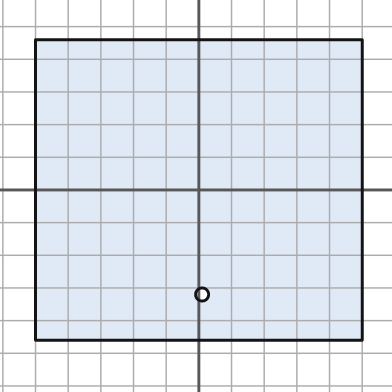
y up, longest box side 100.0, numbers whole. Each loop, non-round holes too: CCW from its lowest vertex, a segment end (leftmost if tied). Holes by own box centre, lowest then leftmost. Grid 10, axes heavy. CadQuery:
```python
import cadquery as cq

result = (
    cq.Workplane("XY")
    .moveTo(-50.0, -46.0)
    .lineTo(50.0, -46.0)
    .lineTo(50.0, 46.0)
    .lineTo(-50.0, 46.0)
    .close()
    .moveTo(1.0, -32.0)
    .circle(2.0)
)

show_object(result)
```